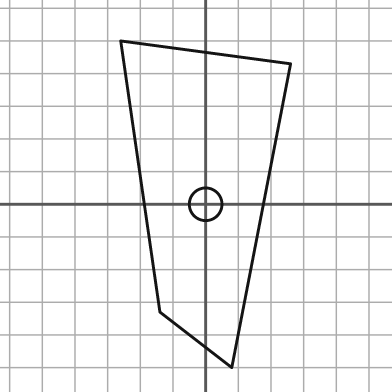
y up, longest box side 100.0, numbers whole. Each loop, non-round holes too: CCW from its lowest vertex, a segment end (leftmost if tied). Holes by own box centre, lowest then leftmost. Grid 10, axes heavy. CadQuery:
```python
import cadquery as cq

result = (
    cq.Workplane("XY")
    .moveTo(8.0, -50.0)
    .lineTo(26.0, 43.0)
    .lineTo(-26.0, 50.0)
    .lineTo(-14.0, -33.0)
    .close()
    .moveTo(0.0, 0.0)
    .circle(5.0)
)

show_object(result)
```